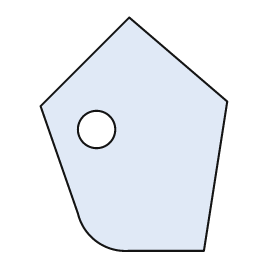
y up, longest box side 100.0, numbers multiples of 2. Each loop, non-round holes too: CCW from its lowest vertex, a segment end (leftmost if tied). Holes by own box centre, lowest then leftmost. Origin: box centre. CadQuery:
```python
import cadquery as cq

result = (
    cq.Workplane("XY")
    .moveTo(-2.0, -50.0)
    .lineTo(30.0, -50.0)
    .lineTo(40.0, 14.0)
    .lineTo(-2.0, 50.0)
    .lineTo(-40.0, 12.0)
    .lineTo(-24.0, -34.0)
    .threePointArc((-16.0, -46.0), (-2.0, -50.0))
    .close()
    .moveTo(-16.0, 2.0)
    .circle(8.0)
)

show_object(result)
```